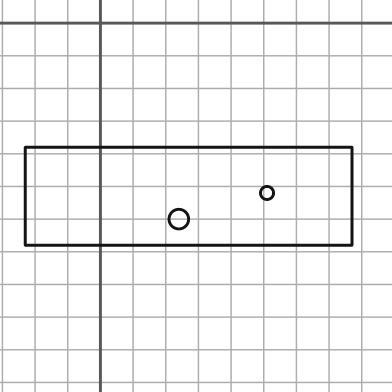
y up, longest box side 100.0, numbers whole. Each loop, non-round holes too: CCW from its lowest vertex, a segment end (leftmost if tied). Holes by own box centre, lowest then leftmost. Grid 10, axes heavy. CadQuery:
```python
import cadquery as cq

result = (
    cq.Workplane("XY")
    .moveTo(-23.0, -68.0)
    .lineTo(77.0, -68.0)
    .lineTo(77.0, -38.0)
    .lineTo(-23.0, -38.0)
    .close()
    .moveTo(24.0, -60.0)
    .circle(3.0)
    .moveTo(51.0, -52.0)
    .circle(2.0)
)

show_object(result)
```